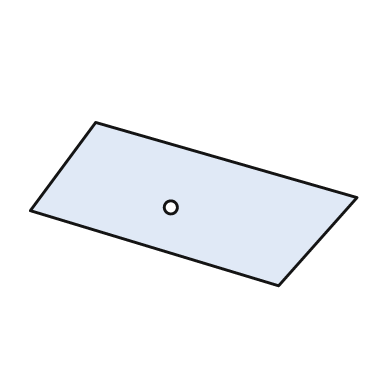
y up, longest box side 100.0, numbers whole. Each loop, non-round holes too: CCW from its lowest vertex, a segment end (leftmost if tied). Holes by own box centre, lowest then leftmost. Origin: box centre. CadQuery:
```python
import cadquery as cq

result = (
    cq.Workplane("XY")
    .moveTo(26.0, -25.0)
    .lineTo(50.0, 2.0)
    .lineTo(-30.0, 25.0)
    .lineTo(-50.0, -2.0)
    .close()
    .moveTo(-7.0, -1.0)
    .circle(2.0)
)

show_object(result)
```